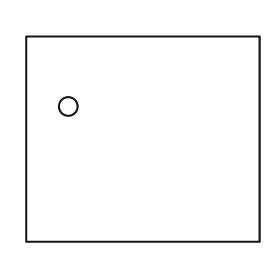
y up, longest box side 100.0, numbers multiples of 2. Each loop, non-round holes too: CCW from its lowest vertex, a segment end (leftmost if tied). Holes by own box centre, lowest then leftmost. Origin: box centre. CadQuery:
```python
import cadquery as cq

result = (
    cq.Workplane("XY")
    .moveTo(-50.0, -44.0)
    .lineTo(50.0, -44.0)
    .lineTo(50.0, 44.0)
    .lineTo(-50.0, 44.0)
    .close()
    .moveTo(-32.0, 14.0)
    .circle(4.0)
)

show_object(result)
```